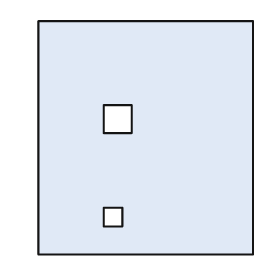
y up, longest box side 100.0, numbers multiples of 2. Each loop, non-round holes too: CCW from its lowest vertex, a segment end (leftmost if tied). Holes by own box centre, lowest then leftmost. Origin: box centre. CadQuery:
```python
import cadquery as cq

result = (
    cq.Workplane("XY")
    .moveTo(-46.0, -50.0)
    .lineTo(46.0, -50.0)
    .lineTo(46.0, 50.0)
    .lineTo(-46.0, 50.0)
    .close()
    .moveTo(-18.0, -38.0)
    .lineTo(-10.0, -38.0)
    .lineTo(-10.0, -30.0)
    .lineTo(-18.0, -30.0)
    .close()
    .moveTo(-18.0, 2.0)
    .lineTo(-6.0, 2.0)
    .lineTo(-6.0, 14.0)
    .lineTo(-18.0, 14.0)
    .close()
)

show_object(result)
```